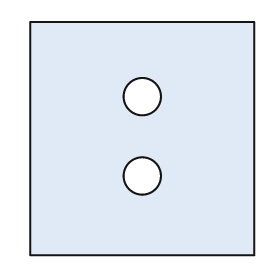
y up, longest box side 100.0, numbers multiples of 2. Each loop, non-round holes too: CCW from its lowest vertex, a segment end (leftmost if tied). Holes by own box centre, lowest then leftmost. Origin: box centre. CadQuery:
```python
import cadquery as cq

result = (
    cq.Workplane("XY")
    .moveTo(-48.0, -50.0)
    .lineTo(48.0, -50.0)
    .lineTo(48.0, 50.0)
    .lineTo(-48.0, 50.0)
    .close()
    .moveTo(0.0, -16.0)
    .circle(8.0)
    .moveTo(0.0, 18.0)
    .circle(8.0)
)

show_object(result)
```